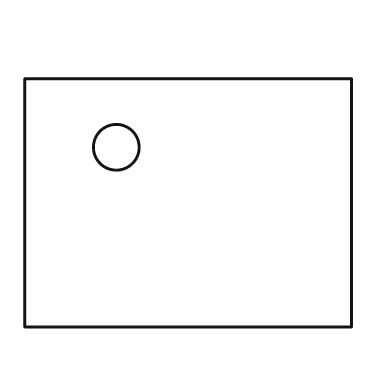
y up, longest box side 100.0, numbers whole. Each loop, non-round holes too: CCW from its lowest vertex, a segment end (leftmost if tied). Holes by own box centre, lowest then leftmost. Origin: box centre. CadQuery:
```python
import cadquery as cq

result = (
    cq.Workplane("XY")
    .moveTo(-50.0, -38.0)
    .lineTo(50.0, -38.0)
    .lineTo(50.0, 38.0)
    .lineTo(-50.0, 38.0)
    .close()
    .moveTo(-22.0, 17.0)
    .circle(7.0)
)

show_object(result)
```